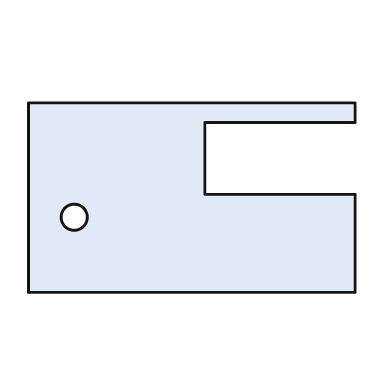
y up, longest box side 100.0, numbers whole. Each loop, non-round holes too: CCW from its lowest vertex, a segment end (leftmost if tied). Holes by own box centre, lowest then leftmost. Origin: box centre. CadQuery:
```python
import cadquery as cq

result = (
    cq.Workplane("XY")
    .moveTo(-50.0, -29.0)
    .lineTo(50.0, -29.0)
    .lineTo(50.0, 1.0)
    .lineTo(4.0, 1.0)
    .lineTo(4.0, 23.0)
    .lineTo(50.0, 23.0)
    .lineTo(50.0, 29.0)
    .lineTo(-50.0, 29.0)
    .close()
    .moveTo(-36.0, -6.0)
    .circle(4.0)
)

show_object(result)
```